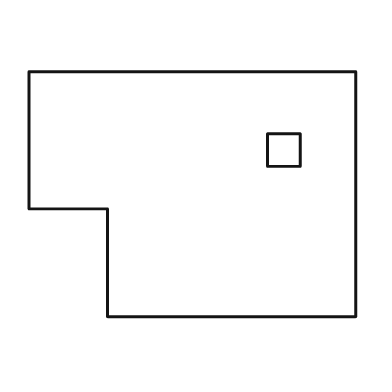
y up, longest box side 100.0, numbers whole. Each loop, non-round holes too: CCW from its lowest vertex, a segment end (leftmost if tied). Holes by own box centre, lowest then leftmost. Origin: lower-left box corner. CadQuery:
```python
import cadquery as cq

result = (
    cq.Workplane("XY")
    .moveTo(24.0, 0.0)
    .lineTo(100.0, 0.0)
    .lineTo(100.0, 75.0)
    .lineTo(0.0, 75.0)
    .lineTo(0.0, 33.0)
    .lineTo(24.0, 33.0)
    .close()
    .moveTo(73.0, 46.0)
    .lineTo(83.0, 46.0)
    .lineTo(83.0, 56.0)
    .lineTo(73.0, 56.0)
    .close()
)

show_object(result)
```